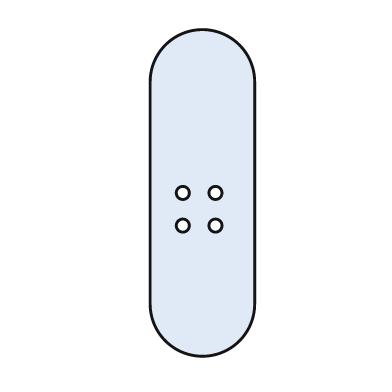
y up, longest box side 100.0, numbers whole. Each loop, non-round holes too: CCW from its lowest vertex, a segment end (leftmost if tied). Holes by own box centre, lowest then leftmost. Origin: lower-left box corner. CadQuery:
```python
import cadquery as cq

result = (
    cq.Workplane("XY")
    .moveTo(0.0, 16.0)
    .threePointArc((16.0, 0.0), (32.0, 16.0))
    .lineTo(32.0, 84.0)
    .threePointArc((16.0, 100.0), (0.0, 84.0))
    .close()
    .moveTo(10.0, 40.0)
    .circle(2.0)
    .moveTo(20.0, 40.0)
    .circle(2.0)
    .moveTo(10.0, 50.0)
    .circle(2.0)
    .moveTo(20.0, 50.0)
    .circle(2.0)
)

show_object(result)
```